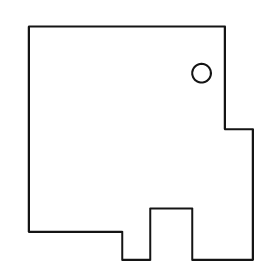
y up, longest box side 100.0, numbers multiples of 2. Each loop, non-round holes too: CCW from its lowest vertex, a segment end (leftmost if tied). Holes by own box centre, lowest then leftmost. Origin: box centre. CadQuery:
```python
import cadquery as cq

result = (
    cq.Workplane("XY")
    .moveTo(-8.0, -50.0)
    .lineTo(4.0, -50.0)
    .lineTo(4.0, -28.0)
    .lineTo(22.0, -28.0)
    .lineTo(22.0, -50.0)
    .lineTo(48.0, -50.0)
    .lineTo(48.0, 6.0)
    .lineTo(36.0, 6.0)
    .lineTo(36.0, 50.0)
    .lineTo(-48.0, 50.0)
    .lineTo(-48.0, -38.0)
    .lineTo(-8.0, -38.0)
    .close()
    .moveTo(26.0, 30.0)
    .circle(4.0)
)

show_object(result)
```